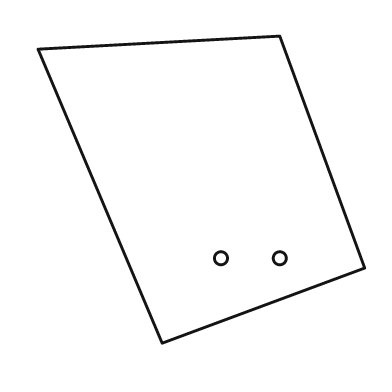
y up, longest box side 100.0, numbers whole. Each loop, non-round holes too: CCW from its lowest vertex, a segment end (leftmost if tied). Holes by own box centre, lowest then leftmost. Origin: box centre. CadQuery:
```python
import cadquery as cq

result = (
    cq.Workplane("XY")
    .moveTo(-12.0, -47.0)
    .lineTo(50.0, -24.0)
    .lineTo(24.0, 47.0)
    .lineTo(-50.0, 43.0)
    .close()
    .moveTo(6.0, -21.0)
    .circle(2.0)
    .moveTo(24.0, -21.0)
    .circle(2.0)
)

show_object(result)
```